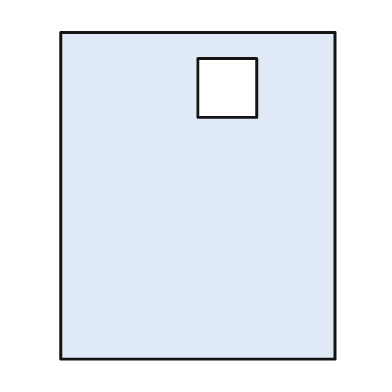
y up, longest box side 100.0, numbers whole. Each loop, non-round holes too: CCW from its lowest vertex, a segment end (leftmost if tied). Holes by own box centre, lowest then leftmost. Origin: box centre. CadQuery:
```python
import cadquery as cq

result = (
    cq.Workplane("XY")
    .moveTo(-42.0, -50.0)
    .lineTo(42.0, -50.0)
    .lineTo(42.0, 50.0)
    .lineTo(-42.0, 50.0)
    .close()
    .moveTo(0.0, 24.0)
    .lineTo(18.0, 24.0)
    .lineTo(18.0, 42.0)
    .lineTo(0.0, 42.0)
    .close()
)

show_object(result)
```